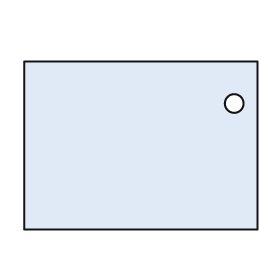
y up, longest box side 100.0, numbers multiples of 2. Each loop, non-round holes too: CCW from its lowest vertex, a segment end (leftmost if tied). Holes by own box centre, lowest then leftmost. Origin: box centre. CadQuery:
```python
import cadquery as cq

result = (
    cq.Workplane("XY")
    .moveTo(-50.0, -36.0)
    .lineTo(50.0, -36.0)
    .lineTo(50.0, 36.0)
    .lineTo(-50.0, 36.0)
    .close()
    .moveTo(40.0, 18.0)
    .circle(4.0)
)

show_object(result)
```